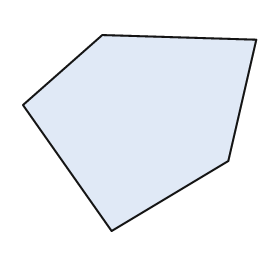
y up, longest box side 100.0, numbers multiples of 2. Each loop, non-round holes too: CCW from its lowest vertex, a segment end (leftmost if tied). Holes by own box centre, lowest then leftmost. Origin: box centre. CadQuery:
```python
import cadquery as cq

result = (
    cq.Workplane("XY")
    .moveTo(-12.0, -42.0)
    .lineTo(38.0, -12.0)
    .lineTo(50.0, 40.0)
    .lineTo(-16.0, 42.0)
    .lineTo(-50.0, 12.0)
    .close()
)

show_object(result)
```